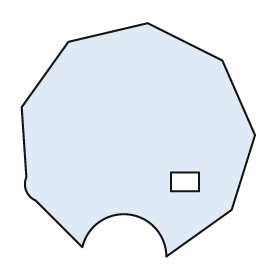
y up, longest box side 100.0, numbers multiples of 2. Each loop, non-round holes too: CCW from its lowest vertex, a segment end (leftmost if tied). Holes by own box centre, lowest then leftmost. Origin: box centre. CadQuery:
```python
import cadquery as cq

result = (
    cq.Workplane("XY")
    .moveTo(12.0, -50.0)
    .lineTo(40.0, -30.0)
    .lineTo(50.0, 2.0)
    .lineTo(36.0, 34.0)
    .lineTo(4.0, 50.0)
    .lineTo(-30.0, 42.0)
    .lineTo(-50.0, 14.0)
    .lineTo(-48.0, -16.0)
    .threePointArc((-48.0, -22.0), (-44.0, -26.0))
    .lineTo(-24.0, -46.0)
    .threePointArc((-4.0, -32.0), (12.0, -50.0))
    .close()
    .moveTo(14.0, -22.0)
    .lineTo(26.0, -22.0)
    .lineTo(26.0, -14.0)
    .lineTo(14.0, -14.0)
    .close()
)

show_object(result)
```